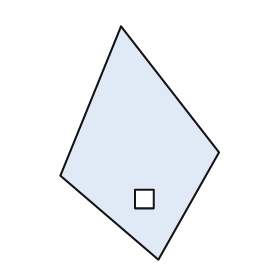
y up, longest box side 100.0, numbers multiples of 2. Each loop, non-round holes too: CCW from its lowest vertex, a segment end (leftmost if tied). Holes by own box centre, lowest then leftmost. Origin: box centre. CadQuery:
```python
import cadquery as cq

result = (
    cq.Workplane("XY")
    .moveTo(8.0, -50.0)
    .lineTo(34.0, -4.0)
    .lineTo(-8.0, 50.0)
    .lineTo(-34.0, -14.0)
    .close()
    .moveTo(-2.0, -28.0)
    .lineTo(6.0, -28.0)
    .lineTo(6.0, -20.0)
    .lineTo(-2.0, -20.0)
    .close()
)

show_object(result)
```